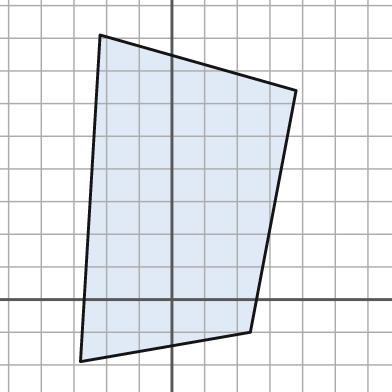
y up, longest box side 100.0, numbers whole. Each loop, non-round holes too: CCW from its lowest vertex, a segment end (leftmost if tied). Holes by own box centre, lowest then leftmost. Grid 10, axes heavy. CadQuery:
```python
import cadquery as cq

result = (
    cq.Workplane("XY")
    .moveTo(-28.0, -19.0)
    .lineTo(24.0, -10.0)
    .lineTo(38.0, 64.0)
    .lineTo(-22.0, 81.0)
    .close()
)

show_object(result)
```